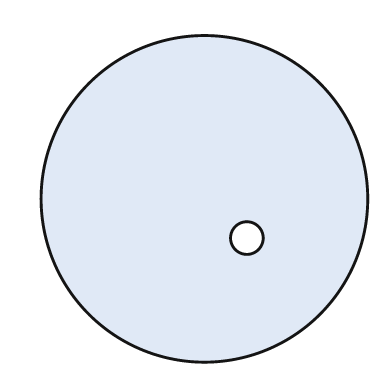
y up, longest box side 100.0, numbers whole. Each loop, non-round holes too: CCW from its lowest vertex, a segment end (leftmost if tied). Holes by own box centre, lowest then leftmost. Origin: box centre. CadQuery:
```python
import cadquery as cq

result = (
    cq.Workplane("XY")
    .moveTo(0.0, 0.0)
    .circle(50.0)
    .moveTo(13.0, -12.0)
    .circle(5.0)
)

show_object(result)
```